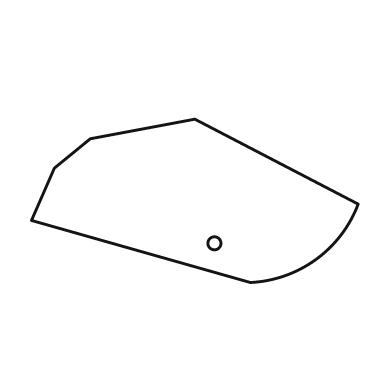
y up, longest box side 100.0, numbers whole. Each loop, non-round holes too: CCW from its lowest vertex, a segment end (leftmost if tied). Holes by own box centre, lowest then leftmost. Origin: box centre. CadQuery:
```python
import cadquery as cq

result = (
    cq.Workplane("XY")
    .moveTo(17.0, -25.0)
    .threePointArc((37.0, -18.0), (50.0, -1.0))
    .lineTo(0.0, 25.0)
    .lineTo(-32.0, 19.0)
    .lineTo(-43.0, 10.0)
    .lineTo(-50.0, -6.0)
    .close()
    .moveTo(6.0, -13.0)
    .circle(2.0)
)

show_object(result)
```